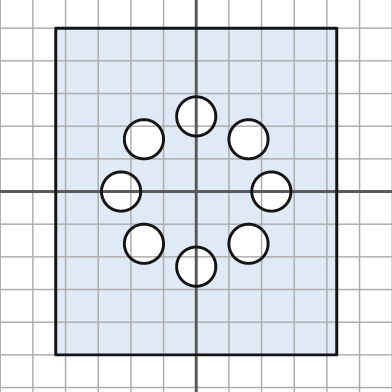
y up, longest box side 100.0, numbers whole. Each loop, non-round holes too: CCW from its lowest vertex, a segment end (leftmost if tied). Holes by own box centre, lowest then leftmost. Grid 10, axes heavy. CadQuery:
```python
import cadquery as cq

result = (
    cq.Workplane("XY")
    .moveTo(-43.0, -50.0)
    .lineTo(43.0, -50.0)
    .lineTo(43.0, 50.0)
    .lineTo(-43.0, 50.0)
    .close()
    .moveTo(0.0, -23.0)
    .circle(6.0)
    .moveTo(-16.0, -16.0)
    .circle(6.0)
    .moveTo(16.0, -16.0)
    .circle(6.0)
    .moveTo(-23.0, 0.0)
    .circle(6.0)
    .moveTo(23.0, 0.0)
    .circle(6.0)
    .moveTo(-16.0, 16.0)
    .circle(6.0)
    .moveTo(16.0, 16.0)
    .circle(6.0)
    .moveTo(0.0, 23.0)
    .circle(6.0)
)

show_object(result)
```